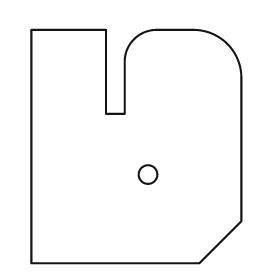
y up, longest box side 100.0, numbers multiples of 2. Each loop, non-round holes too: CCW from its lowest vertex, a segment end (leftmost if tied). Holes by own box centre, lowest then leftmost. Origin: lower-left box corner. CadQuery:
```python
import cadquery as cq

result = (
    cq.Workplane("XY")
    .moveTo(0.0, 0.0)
    .lineTo(72.0, 0.0)
    .lineTo(90.0, 18.0)
    .lineTo(90.0, 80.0)
    .threePointArc((84.0, 94.0), (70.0, 100.0))
    .lineTo(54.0, 100.0)
    .threePointArc((44.0, 96.0), (40.0, 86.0))
    .lineTo(40.0, 64.0)
    .lineTo(32.0, 64.0)
    .lineTo(32.0, 100.0)
    .lineTo(0.0, 100.0)
    .close()
    .moveTo(50.0, 38.0)
    .circle(4.0)
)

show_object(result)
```